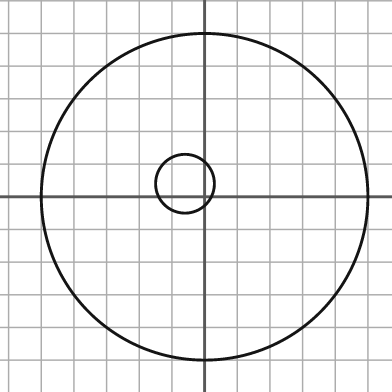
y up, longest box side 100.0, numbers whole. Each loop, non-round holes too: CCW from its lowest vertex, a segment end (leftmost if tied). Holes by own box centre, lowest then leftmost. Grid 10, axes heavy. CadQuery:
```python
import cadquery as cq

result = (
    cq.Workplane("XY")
    .moveTo(0.0, 0.0)
    .circle(50.0)
    .moveTo(-6.0, 4.0)
    .circle(9.0)
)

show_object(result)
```